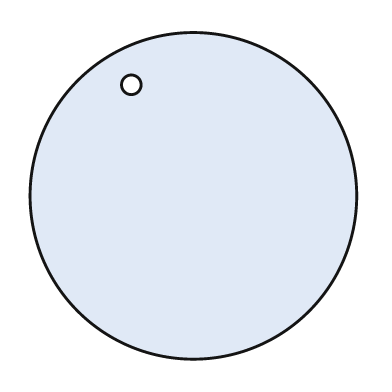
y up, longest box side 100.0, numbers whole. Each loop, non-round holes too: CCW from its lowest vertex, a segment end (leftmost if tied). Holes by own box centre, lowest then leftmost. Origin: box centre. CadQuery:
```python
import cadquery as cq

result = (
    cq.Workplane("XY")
    .moveTo(0.0, 0.0)
    .circle(50.0)
    .moveTo(-19.0, 34.0)
    .circle(3.0)
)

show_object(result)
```